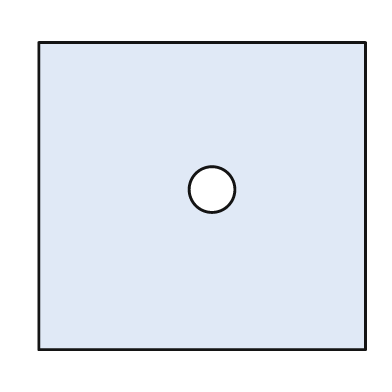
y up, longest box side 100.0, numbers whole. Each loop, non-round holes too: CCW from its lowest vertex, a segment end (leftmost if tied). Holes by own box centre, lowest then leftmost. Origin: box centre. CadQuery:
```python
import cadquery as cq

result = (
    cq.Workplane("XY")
    .moveTo(-50.0, -47.0)
    .lineTo(50.0, -47.0)
    .lineTo(50.0, 47.0)
    .lineTo(-50.0, 47.0)
    .close()
    .moveTo(3.0, 2.0)
    .circle(7.0)
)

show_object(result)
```